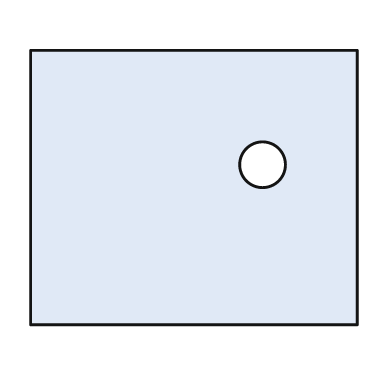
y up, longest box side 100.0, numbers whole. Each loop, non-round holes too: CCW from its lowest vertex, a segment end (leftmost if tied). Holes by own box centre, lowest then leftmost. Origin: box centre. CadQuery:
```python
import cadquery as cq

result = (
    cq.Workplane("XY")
    .moveTo(-50.0, -42.0)
    .lineTo(50.0, -42.0)
    .lineTo(50.0, 42.0)
    .lineTo(-50.0, 42.0)
    .close()
    .moveTo(21.0, 7.0)
    .circle(7.0)
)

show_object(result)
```